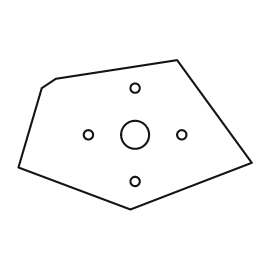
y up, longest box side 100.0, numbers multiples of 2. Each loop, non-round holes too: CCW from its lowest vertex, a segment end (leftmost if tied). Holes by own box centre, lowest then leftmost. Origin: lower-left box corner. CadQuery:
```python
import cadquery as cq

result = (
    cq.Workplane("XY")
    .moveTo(48.0, 0.0)
    .lineTo(100.0, 20.0)
    .lineTo(68.0, 64.0)
    .lineTo(16.0, 56.0)
    .lineTo(10.0, 52.0)
    .lineTo(0.0, 18.0)
    .close()
    .moveTo(50.0, 12.0)
    .circle(2.0)
    .moveTo(30.0, 32.0)
    .circle(2.0)
    .moveTo(50.0, 32.0)
    .circle(6.0)
    .moveTo(70.0, 32.0)
    .circle(2.0)
    .moveTo(50.0, 52.0)
    .circle(2.0)
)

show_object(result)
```